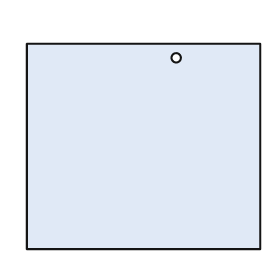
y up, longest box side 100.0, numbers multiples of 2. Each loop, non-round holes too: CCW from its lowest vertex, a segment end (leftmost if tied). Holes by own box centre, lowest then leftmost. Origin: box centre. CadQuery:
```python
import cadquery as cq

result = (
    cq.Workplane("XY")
    .moveTo(-50.0, -44.0)
    .lineTo(50.0, -44.0)
    .lineTo(50.0, 44.0)
    .lineTo(-50.0, 44.0)
    .close()
    .moveTo(14.0, 38.0)
    .circle(2.0)
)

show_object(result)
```